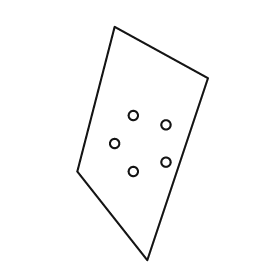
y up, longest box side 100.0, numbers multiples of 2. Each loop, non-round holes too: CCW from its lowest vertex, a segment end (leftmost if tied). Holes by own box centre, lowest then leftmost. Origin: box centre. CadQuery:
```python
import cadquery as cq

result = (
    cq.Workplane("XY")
    .moveTo(2.0, -50.0)
    .lineTo(28.0, 28.0)
    .lineTo(-12.0, 50.0)
    .lineTo(-28.0, -12.0)
    .close()
    .moveTo(-4.0, -12.0)
    .circle(2.0)
    .moveTo(10.0, -8.0)
    .circle(2.0)
    .moveTo(-12.0, 0.0)
    .circle(2.0)
    .moveTo(10.0, 8.0)
    .circle(2.0)
    .moveTo(-4.0, 12.0)
    .circle(2.0)
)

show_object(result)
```